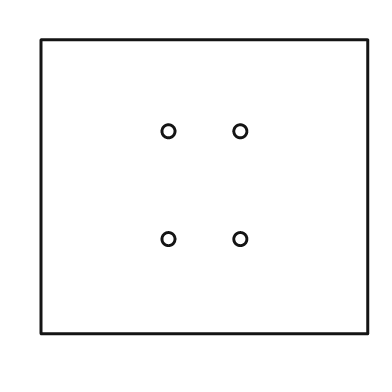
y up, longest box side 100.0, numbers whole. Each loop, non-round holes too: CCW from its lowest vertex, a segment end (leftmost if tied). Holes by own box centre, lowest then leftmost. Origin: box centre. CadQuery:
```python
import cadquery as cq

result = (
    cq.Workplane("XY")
    .moveTo(-50.0, -45.0)
    .lineTo(50.0, -45.0)
    .lineTo(50.0, 45.0)
    .lineTo(-50.0, 45.0)
    .close()
    .moveTo(-11.0, -16.0)
    .circle(2.0)
    .moveTo(11.0, -16.0)
    .circle(2.0)
    .moveTo(-11.0, 17.0)
    .circle(2.0)
    .moveTo(11.0, 17.0)
    .circle(2.0)
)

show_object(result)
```